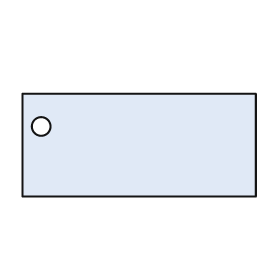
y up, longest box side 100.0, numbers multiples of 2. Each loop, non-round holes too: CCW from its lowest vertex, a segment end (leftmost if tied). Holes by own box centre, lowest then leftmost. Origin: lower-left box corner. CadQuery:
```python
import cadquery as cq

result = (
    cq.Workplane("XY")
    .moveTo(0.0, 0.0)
    .lineTo(100.0, 0.0)
    .lineTo(100.0, 44.0)
    .lineTo(0.0, 44.0)
    .close()
    .moveTo(8.0, 30.0)
    .circle(4.0)
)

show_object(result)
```